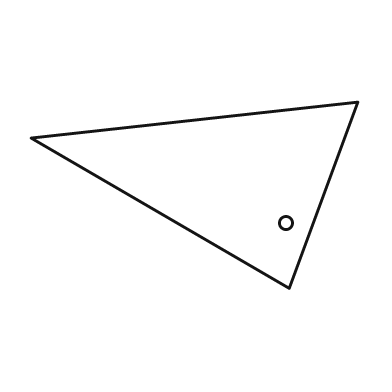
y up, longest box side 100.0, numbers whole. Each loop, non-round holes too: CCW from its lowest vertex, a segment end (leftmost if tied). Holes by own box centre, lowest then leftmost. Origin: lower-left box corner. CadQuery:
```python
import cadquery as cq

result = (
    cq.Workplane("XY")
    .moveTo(79.0, 0.0)
    .lineTo(100.0, 57.0)
    .lineTo(0.0, 46.0)
    .close()
    .moveTo(78.0, 20.0)
    .circle(2.0)
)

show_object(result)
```